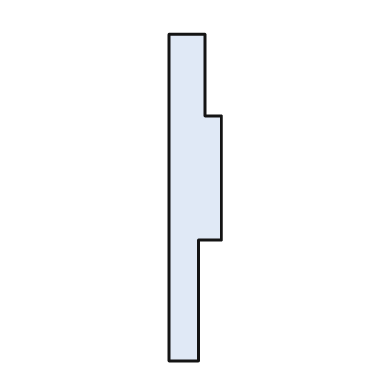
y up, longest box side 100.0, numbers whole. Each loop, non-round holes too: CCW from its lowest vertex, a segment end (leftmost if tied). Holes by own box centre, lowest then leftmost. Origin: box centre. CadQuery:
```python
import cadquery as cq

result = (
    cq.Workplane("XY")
    .moveTo(-8.0, -50.0)
    .lineTo(1.0, -50.0)
    .lineTo(1.0, -13.0)
    .lineTo(8.0, -13.0)
    .lineTo(8.0, 25.0)
    .lineTo(3.0, 25.0)
    .lineTo(3.0, 50.0)
    .lineTo(-8.0, 50.0)
    .close()
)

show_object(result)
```